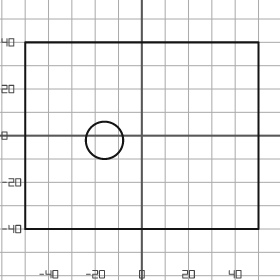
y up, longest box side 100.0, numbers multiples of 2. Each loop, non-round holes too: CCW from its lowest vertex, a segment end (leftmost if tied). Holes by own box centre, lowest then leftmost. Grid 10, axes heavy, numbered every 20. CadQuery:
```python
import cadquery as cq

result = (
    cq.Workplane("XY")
    .moveTo(-50.0, -40.0)
    .lineTo(50.0, -40.0)
    .lineTo(50.0, 40.0)
    .lineTo(-50.0, 40.0)
    .close()
    .moveTo(-16.0, -2.0)
    .circle(8.0)
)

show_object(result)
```